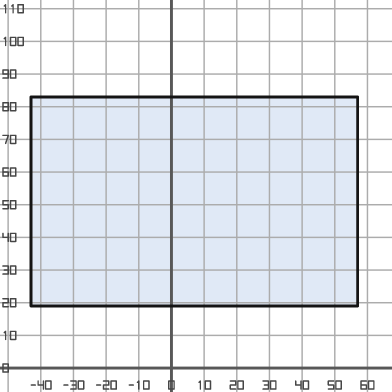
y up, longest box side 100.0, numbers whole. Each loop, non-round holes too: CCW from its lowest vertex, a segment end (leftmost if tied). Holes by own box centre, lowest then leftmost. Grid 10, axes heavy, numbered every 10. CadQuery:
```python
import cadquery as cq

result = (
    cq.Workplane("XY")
    .moveTo(-43.0, 19.0)
    .lineTo(57.0, 19.0)
    .lineTo(57.0, 83.0)
    .lineTo(-43.0, 83.0)
    .close()
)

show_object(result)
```